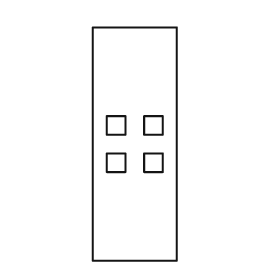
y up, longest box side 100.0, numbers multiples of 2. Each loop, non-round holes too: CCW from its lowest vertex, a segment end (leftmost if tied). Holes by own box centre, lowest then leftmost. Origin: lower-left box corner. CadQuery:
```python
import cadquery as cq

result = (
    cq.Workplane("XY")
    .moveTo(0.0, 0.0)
    .lineTo(36.0, 0.0)
    .lineTo(36.0, 100.0)
    .lineTo(0.0, 100.0)
    .close()
    .moveTo(6.0, 38.0)
    .lineTo(14.0, 38.0)
    .lineTo(14.0, 46.0)
    .lineTo(6.0, 46.0)
    .close()
    .moveTo(22.0, 38.0)
    .lineTo(30.0, 38.0)
    .lineTo(30.0, 46.0)
    .lineTo(22.0, 46.0)
    .close()
    .moveTo(6.0, 54.0)
    .lineTo(14.0, 54.0)
    .lineTo(14.0, 62.0)
    .lineTo(6.0, 62.0)
    .close()
    .moveTo(22.0, 54.0)
    .lineTo(30.0, 54.0)
    .lineTo(30.0, 62.0)
    .lineTo(22.0, 62.0)
    .close()
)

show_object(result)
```